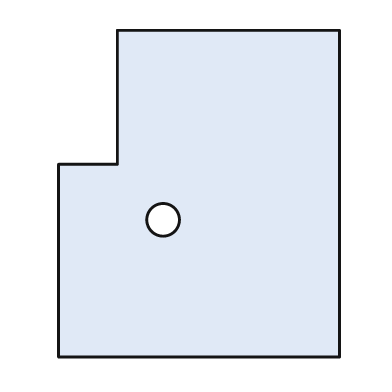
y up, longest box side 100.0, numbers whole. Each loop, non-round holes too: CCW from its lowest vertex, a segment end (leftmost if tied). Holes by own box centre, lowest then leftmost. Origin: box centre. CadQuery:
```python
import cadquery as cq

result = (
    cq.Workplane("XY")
    .moveTo(-43.0, -50.0)
    .lineTo(43.0, -50.0)
    .lineTo(43.0, 50.0)
    .lineTo(-25.0, 50.0)
    .lineTo(-25.0, 9.0)
    .lineTo(-43.0, 9.0)
    .close()
    .moveTo(-11.0, -8.0)
    .circle(5.0)
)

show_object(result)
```